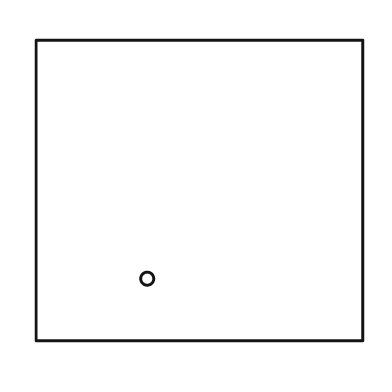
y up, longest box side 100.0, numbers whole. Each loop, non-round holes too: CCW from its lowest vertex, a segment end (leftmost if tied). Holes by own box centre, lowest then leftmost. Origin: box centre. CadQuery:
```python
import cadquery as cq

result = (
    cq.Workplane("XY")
    .moveTo(-50.0, -46.0)
    .lineTo(50.0, -46.0)
    .lineTo(50.0, 46.0)
    .lineTo(-50.0, 46.0)
    .close()
    .moveTo(-16.0, -27.0)
    .circle(2.0)
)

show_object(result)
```